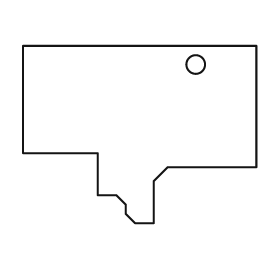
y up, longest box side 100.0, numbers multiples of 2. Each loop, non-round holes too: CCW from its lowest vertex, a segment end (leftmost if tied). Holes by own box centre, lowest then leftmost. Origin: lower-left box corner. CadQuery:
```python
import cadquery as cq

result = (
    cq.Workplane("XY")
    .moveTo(48.0, 0.0)
    .lineTo(56.0, 0.0)
    .lineTo(56.0, 18.0)
    .lineTo(62.0, 24.0)
    .lineTo(100.0, 24.0)
    .lineTo(100.0, 76.0)
    .lineTo(0.0, 76.0)
    .lineTo(0.0, 30.0)
    .lineTo(32.0, 30.0)
    .lineTo(32.0, 12.0)
    .lineTo(40.0, 12.0)
    .lineTo(44.0, 8.0)
    .lineTo(44.0, 4.0)
    .close()
    .moveTo(74.0, 68.0)
    .circle(4.0)
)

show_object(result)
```